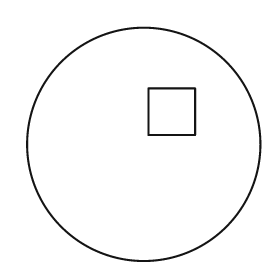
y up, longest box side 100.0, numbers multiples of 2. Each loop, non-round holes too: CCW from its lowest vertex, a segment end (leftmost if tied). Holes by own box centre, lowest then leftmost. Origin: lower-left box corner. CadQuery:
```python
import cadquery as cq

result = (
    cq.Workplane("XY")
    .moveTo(50.0, 50.0)
    .circle(50.0)
    .moveTo(52.0, 54.0)
    .lineTo(72.0, 54.0)
    .lineTo(72.0, 74.0)
    .lineTo(52.0, 74.0)
    .close()
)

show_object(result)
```